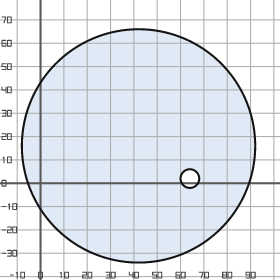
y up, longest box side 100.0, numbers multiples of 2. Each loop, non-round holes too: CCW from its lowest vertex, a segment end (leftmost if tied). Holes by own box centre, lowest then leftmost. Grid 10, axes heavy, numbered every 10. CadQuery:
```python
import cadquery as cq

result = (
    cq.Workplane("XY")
    .moveTo(42.0, 16.0)
    .circle(50.0)
    .moveTo(64.0, 2.0)
    .circle(4.0)
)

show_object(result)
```